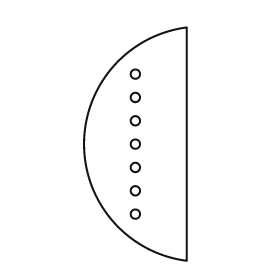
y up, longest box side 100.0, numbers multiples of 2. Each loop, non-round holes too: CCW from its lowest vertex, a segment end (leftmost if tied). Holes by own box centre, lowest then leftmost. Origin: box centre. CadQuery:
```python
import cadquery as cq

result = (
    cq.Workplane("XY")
    .moveTo(22.0, -50.0)
    .lineTo(22.0, 50.0)
    .threePointArc((-22.0, 0.0), (22.0, -50.0))
    .close()
    .moveTo(0.0, -30.0)
    .circle(2.0)
    .moveTo(0.0, -20.0)
    .circle(2.0)
    .moveTo(0.0, -10.0)
    .circle(2.0)
    .moveTo(0.0, 0.0)
    .circle(2.0)
    .moveTo(0.0, 10.0)
    .circle(2.0)
    .moveTo(0.0, 20.0)
    .circle(2.0)
    .moveTo(0.0, 30.0)
    .circle(2.0)
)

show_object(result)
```